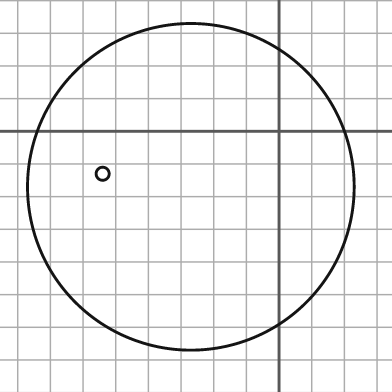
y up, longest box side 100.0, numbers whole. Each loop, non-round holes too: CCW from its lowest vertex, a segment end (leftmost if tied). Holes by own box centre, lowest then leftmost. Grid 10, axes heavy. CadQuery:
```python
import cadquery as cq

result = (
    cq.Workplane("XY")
    .moveTo(-27.0, -17.0)
    .circle(50.0)
    .moveTo(-54.0, -13.0)
    .circle(2.0)
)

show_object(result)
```